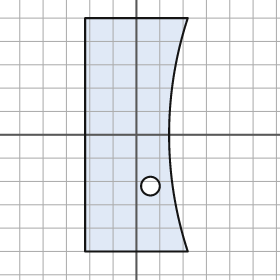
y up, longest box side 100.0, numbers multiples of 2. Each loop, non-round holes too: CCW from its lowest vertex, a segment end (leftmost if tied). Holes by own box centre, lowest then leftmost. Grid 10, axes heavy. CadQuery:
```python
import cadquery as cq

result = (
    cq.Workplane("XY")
    .moveTo(-22.0, -50.0)
    .lineTo(22.0, -50.0)
    .threePointArc((14.0, 0.0), (22.0, 50.0))
    .lineTo(-22.0, 50.0)
    .close()
    .moveTo(6.0, -22.0)
    .circle(4.0)
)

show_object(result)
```